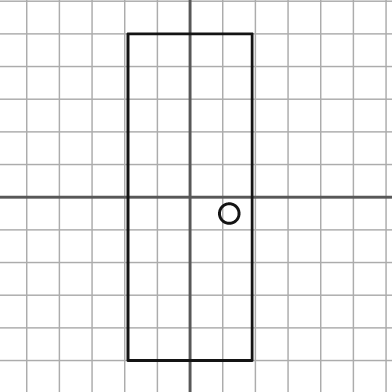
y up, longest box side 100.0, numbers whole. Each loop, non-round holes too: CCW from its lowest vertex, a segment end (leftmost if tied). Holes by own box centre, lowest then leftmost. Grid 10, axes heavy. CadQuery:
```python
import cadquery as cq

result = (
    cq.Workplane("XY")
    .moveTo(-19.0, -50.0)
    .lineTo(19.0, -50.0)
    .lineTo(19.0, 50.0)
    .lineTo(-19.0, 50.0)
    .close()
    .moveTo(12.0, -5.0)
    .circle(3.0)
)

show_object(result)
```